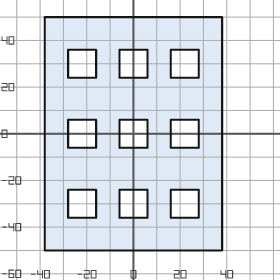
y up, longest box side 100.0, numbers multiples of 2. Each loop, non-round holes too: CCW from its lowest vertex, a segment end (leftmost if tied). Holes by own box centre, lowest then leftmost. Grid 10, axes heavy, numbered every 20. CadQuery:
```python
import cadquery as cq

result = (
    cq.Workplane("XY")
    .moveTo(-38.0, -50.0)
    .lineTo(38.0, -50.0)
    .lineTo(38.0, 50.0)
    .lineTo(-38.0, 50.0)
    .close()
    .moveTo(-28.0, -36.0)
    .lineTo(-16.0, -36.0)
    .lineTo(-16.0, -24.0)
    .lineTo(-28.0, -24.0)
    .close()
    .moveTo(-6.0, -36.0)
    .lineTo(6.0, -36.0)
    .lineTo(6.0, -24.0)
    .lineTo(-6.0, -24.0)
    .close()
    .moveTo(16.0, -36.0)
    .lineTo(28.0, -36.0)
    .lineTo(28.0, -24.0)
    .lineTo(16.0, -24.0)
    .close()
    .moveTo(-28.0, -6.0)
    .lineTo(-16.0, -6.0)
    .lineTo(-16.0, 6.0)
    .lineTo(-28.0, 6.0)
    .close()
    .moveTo(-6.0, -6.0)
    .lineTo(6.0, -6.0)
    .lineTo(6.0, 6.0)
    .lineTo(-6.0, 6.0)
    .close()
    .moveTo(16.0, -6.0)
    .lineTo(28.0, -6.0)
    .lineTo(28.0, 6.0)
    .lineTo(16.0, 6.0)
    .close()
    .moveTo(-28.0, 24.0)
    .lineTo(-16.0, 24.0)
    .lineTo(-16.0, 36.0)
    .lineTo(-28.0, 36.0)
    .close()
    .moveTo(-6.0, 24.0)
    .lineTo(6.0, 24.0)
    .lineTo(6.0, 36.0)
    .lineTo(-6.0, 36.0)
    .close()
    .moveTo(16.0, 24.0)
    .lineTo(28.0, 24.0)
    .lineTo(28.0, 36.0)
    .lineTo(16.0, 36.0)
    .close()
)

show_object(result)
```